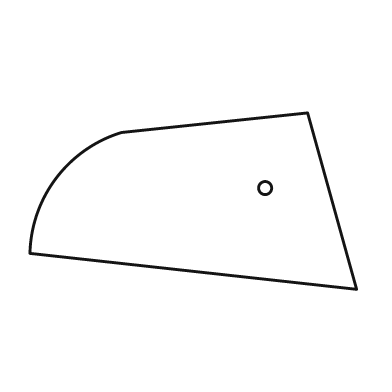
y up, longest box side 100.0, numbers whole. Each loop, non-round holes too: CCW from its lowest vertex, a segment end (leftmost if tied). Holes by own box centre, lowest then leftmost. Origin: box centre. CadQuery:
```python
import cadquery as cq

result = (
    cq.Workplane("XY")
    .moveTo(50.0, -27.0)
    .lineTo(35.0, 27.0)
    .lineTo(-22.0, 21.0)
    .threePointArc((-42.0, 7.0), (-50.0, -16.0))
    .close()
    .moveTo(22.0, 4.0)
    .circle(2.0)
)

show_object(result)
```